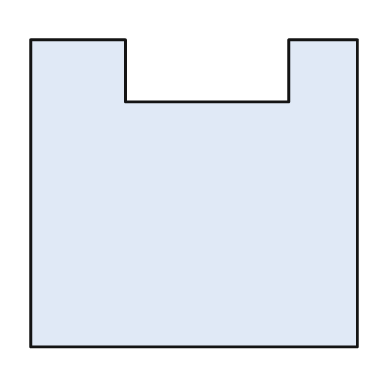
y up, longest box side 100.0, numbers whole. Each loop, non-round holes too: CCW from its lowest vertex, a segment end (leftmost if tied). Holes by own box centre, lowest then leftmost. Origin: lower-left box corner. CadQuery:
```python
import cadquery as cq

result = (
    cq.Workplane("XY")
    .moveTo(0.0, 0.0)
    .lineTo(100.0, 0.0)
    .lineTo(100.0, 94.0)
    .lineTo(79.0, 94.0)
    .lineTo(79.0, 75.0)
    .lineTo(29.0, 75.0)
    .lineTo(29.0, 94.0)
    .lineTo(0.0, 94.0)
    .close()
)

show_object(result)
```